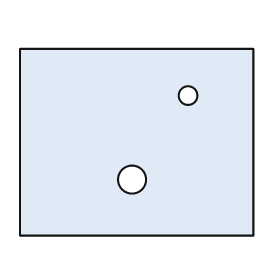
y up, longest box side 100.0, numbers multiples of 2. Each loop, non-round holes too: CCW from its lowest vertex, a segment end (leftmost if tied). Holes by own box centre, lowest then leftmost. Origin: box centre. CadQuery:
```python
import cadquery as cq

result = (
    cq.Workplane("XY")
    .moveTo(-50.0, -40.0)
    .lineTo(50.0, -40.0)
    .lineTo(50.0, 40.0)
    .lineTo(-50.0, 40.0)
    .close()
    .moveTo(-2.0, -16.0)
    .circle(6.0)
    .moveTo(22.0, 20.0)
    .circle(4.0)
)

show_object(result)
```